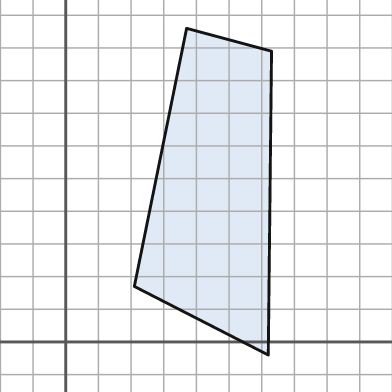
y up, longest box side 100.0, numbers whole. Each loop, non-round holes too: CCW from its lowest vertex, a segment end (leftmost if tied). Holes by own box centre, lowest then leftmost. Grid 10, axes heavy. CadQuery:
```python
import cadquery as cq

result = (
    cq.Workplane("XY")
    .moveTo(62.0, -4.0)
    .lineTo(63.0, 89.0)
    .lineTo(37.0, 96.0)
    .lineTo(21.0, 17.0)
    .close()
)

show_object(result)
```